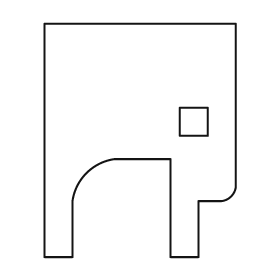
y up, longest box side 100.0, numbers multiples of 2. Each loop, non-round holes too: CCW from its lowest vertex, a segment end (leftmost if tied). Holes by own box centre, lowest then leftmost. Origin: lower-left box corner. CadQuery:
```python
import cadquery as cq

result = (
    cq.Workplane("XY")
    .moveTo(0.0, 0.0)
    .lineTo(12.0, 0.0)
    .lineTo(12.0, 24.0)
    .threePointArc((18.0, 36.0), (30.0, 42.0))
    .lineTo(54.0, 42.0)
    .lineTo(54.0, 0.0)
    .lineTo(66.0, 0.0)
    .lineTo(66.0, 24.0)
    .lineTo(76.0, 24.0)
    .threePointArc((80.0, 26.0), (82.0, 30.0))
    .lineTo(82.0, 100.0)
    .lineTo(0.0, 100.0)
    .close()
    .moveTo(58.0, 52.0)
    .lineTo(70.0, 52.0)
    .lineTo(70.0, 64.0)
    .lineTo(58.0, 64.0)
    .close()
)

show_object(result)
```